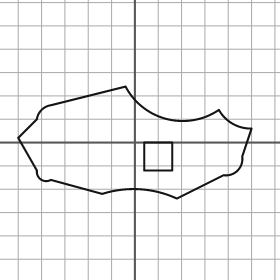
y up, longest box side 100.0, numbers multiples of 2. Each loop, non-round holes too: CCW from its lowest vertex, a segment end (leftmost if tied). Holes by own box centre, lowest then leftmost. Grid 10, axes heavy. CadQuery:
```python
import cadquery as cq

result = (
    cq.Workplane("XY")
    .moveTo(18.0, -24.0)
    .lineTo(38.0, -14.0)
    .threePointArc((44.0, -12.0), (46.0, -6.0))
    .lineTo(50.0, 6.0)
    .threePointArc((42.0, 8.0), (36.0, 14.0))
    .threePointArc((14.0, 10.0), (-4.0, 24.0))
    .lineTo(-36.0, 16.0)
    .threePointArc((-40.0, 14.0), (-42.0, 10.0))
    .lineTo(-50.0, 2.0)
    .lineTo(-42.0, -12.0)
    .threePointArc((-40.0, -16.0), (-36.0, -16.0))
    .lineTo(-14.0, -22.0)
    .threePointArc((2.0, -20.0), (18.0, -24.0))
    .close()
    .moveTo(4.0, -12.0)
    .lineTo(16.0, -12.0)
    .lineTo(16.0, 0.0)
    .lineTo(4.0, 0.0)
    .close()
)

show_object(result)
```